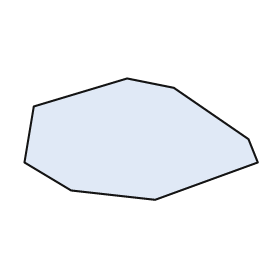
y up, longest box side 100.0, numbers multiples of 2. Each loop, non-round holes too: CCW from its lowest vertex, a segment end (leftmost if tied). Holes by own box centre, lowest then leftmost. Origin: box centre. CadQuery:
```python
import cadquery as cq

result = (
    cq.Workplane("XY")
    .moveTo(6.0, -26.0)
    .lineTo(50.0, -10.0)
    .lineTo(46.0, 0.0)
    .lineTo(14.0, 22.0)
    .lineTo(-6.0, 26.0)
    .lineTo(-46.0, 14.0)
    .lineTo(-50.0, -10.0)
    .lineTo(-30.0, -22.0)
    .close()
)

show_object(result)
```